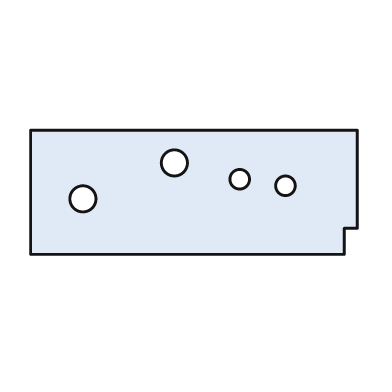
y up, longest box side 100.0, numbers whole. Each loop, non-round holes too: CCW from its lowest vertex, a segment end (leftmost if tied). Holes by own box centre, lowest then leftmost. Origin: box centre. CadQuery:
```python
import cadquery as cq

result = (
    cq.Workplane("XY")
    .moveTo(-50.0, -19.0)
    .lineTo(46.0, -19.0)
    .lineTo(46.0, -11.0)
    .lineTo(50.0, -11.0)
    .lineTo(50.0, 19.0)
    .lineTo(-50.0, 19.0)
    .close()
    .moveTo(-34.0, -2.0)
    .circle(4.0)
    .moveTo(28.0, 2.0)
    .circle(3.0)
    .moveTo(14.0, 4.0)
    .circle(3.0)
    .moveTo(-6.0, 9.0)
    .circle(4.0)
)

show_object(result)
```